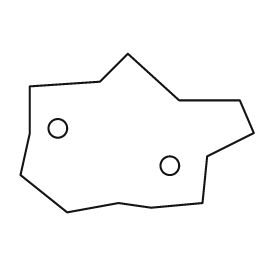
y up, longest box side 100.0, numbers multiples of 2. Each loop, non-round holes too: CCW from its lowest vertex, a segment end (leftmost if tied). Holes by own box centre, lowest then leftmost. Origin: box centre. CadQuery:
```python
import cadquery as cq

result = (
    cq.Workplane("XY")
    .moveTo(-30.0, -34.0)
    .lineTo(-8.0, -30.0)
    .lineTo(6.0, -32.0)
    .lineTo(28.0, -30.0)
    .lineTo(30.0, -10.0)
    .lineTo(50.0, 0.0)
    .lineTo(44.0, 14.0)
    .lineTo(18.0, 14.0)
    .lineTo(-4.0, 34.0)
    .lineTo(-16.0, 22.0)
    .lineTo(-46.0, 20.0)
    .lineTo(-46.0, 0.0)
    .lineTo(-50.0, -18.0)
    .close()
    .moveTo(14.0, -14.0)
    .circle(4.0)
    .moveTo(-34.0, 2.0)
    .circle(4.0)
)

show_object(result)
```